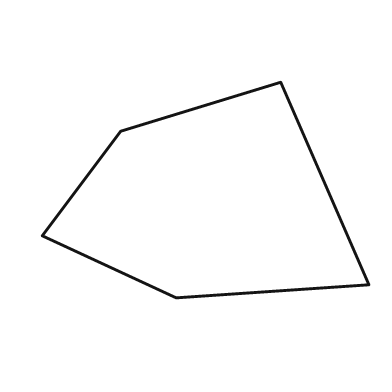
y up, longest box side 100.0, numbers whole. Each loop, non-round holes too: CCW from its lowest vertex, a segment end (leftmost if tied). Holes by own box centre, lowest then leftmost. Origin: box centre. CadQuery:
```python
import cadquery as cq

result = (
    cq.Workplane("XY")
    .moveTo(-9.0, -33.0)
    .lineTo(50.0, -29.0)
    .lineTo(23.0, 33.0)
    .lineTo(-26.0, 18.0)
    .lineTo(-50.0, -14.0)
    .close()
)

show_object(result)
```